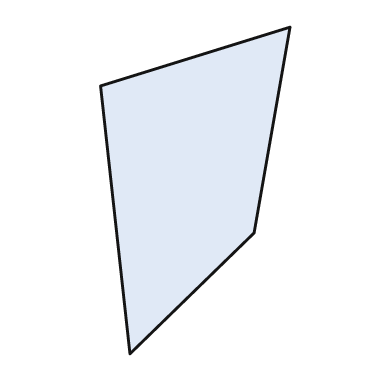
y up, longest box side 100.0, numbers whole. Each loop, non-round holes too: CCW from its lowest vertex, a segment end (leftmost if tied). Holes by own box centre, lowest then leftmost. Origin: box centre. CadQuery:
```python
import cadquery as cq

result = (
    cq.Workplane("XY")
    .moveTo(-20.0, -50.0)
    .lineTo(18.0, -13.0)
    .lineTo(29.0, 50.0)
    .lineTo(-29.0, 32.0)
    .close()
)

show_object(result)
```